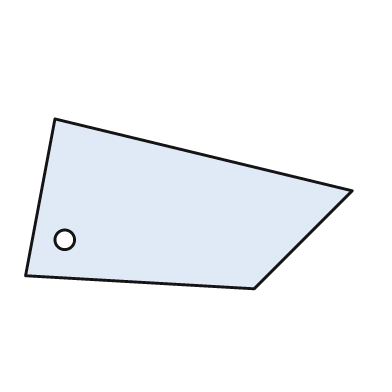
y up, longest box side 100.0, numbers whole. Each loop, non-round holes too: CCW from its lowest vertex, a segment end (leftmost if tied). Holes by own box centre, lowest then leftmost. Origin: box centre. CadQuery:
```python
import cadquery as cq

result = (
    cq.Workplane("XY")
    .moveTo(20.0, -26.0)
    .lineTo(50.0, 4.0)
    .lineTo(-41.0, 26.0)
    .lineTo(-50.0, -22.0)
    .close()
    .moveTo(-38.0, -11.0)
    .circle(3.0)
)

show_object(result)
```